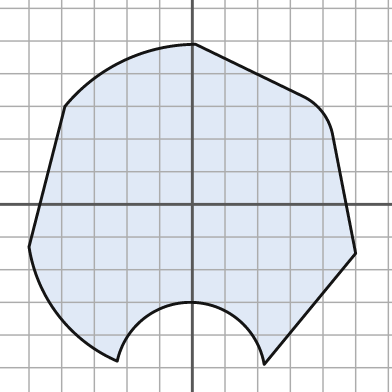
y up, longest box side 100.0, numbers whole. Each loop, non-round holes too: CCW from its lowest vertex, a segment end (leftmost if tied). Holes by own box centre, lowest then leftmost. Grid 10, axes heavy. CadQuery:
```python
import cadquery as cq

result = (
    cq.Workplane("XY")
    .moveTo(22.0, -49.0)
    .lineTo(50.0, -15.0)
    .lineTo(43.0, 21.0)
    .threePointArc((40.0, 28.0), (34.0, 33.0))
    .lineTo(1.0, 49.0)
    .threePointArc((-21.0, 44.0), (-39.0, 30.0))
    .lineTo(-50.0, -13.0)
    .threePointArc((-41.0, -34.0), (-23.0, -48.0))
    .threePointArc((0.0, -30.0), (22.0, -49.0))
    .close()
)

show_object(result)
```